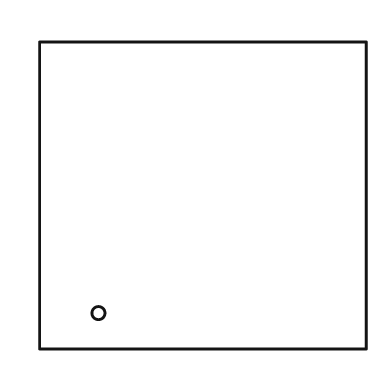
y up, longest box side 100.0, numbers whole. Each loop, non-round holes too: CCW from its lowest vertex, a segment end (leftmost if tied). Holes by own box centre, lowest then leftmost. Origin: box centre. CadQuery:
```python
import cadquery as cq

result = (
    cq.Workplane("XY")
    .moveTo(-50.0, -47.0)
    .lineTo(50.0, -47.0)
    .lineTo(50.0, 47.0)
    .lineTo(-50.0, 47.0)
    .close()
    .moveTo(-32.0, -36.0)
    .circle(2.0)
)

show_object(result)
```